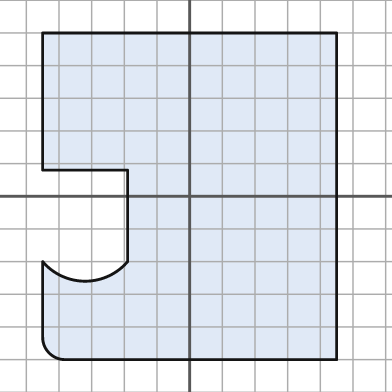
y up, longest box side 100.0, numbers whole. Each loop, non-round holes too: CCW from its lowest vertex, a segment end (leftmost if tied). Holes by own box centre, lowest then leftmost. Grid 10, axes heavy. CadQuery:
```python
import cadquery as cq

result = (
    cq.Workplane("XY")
    .moveTo(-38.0, -50.0)
    .lineTo(45.0, -50.0)
    .lineTo(45.0, 50.0)
    .lineTo(-45.0, 50.0)
    .lineTo(-45.0, 8.0)
    .lineTo(-19.0, 8.0)
    .lineTo(-19.0, -20.0)
    .threePointArc((-32.0, -26.0), (-45.0, -20.0))
    .lineTo(-45.0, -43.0)
    .threePointArc((-43.0, -48.0), (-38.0, -50.0))
    .close()
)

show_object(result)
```